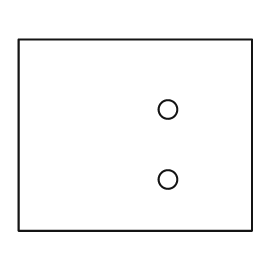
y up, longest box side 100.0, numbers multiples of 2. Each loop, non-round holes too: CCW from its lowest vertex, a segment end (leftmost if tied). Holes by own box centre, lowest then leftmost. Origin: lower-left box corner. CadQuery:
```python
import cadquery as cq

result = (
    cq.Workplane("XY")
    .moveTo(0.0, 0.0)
    .lineTo(100.0, 0.0)
    .lineTo(100.0, 82.0)
    .lineTo(0.0, 82.0)
    .close()
    .moveTo(64.0, 22.0)
    .circle(4.0)
    .moveTo(64.0, 52.0)
    .circle(4.0)
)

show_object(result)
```